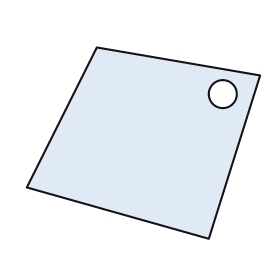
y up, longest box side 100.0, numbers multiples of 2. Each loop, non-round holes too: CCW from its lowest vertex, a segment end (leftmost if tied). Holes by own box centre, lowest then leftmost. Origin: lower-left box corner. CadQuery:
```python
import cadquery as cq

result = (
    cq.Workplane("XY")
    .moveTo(78.0, 0.0)
    .lineTo(100.0, 70.0)
    .lineTo(30.0, 82.0)
    .lineTo(0.0, 22.0)
    .close()
    .moveTo(84.0, 62.0)
    .circle(6.0)
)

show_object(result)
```